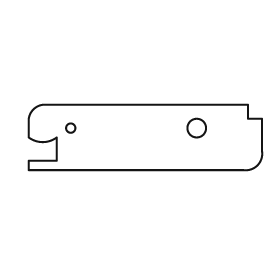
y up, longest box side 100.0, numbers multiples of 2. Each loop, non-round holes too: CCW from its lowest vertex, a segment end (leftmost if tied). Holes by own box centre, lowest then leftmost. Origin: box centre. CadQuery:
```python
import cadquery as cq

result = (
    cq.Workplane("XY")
    .moveTo(-50.0, -14.0)
    .lineTo(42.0, -14.0)
    .threePointArc((48.0, -12.0), (50.0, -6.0))
    .lineTo(50.0, 8.0)
    .lineTo(44.0, 8.0)
    .lineTo(44.0, 14.0)
    .lineTo(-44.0, 14.0)
    .threePointArc((-48.0, 12.0), (-50.0, 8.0))
    .lineTo(-50.0, 0.0)
    .threePointArc((-44.0, -2.0), (-38.0, 0.0))
    .lineTo(-38.0, -10.0)
    .lineTo(-50.0, -10.0)
    .close()
    .moveTo(-32.0, 4.0)
    .circle(2.0)
    .moveTo(22.0, 4.0)
    .circle(4.0)
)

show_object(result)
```